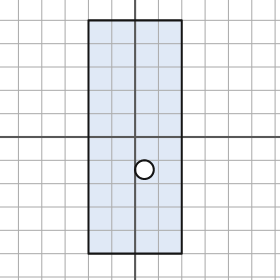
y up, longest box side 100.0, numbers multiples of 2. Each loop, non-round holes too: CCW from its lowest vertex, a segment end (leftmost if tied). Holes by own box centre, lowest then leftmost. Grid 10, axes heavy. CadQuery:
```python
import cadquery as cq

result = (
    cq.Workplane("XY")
    .moveTo(-20.0, -50.0)
    .lineTo(20.0, -50.0)
    .lineTo(20.0, 50.0)
    .lineTo(-20.0, 50.0)
    .close()
    .moveTo(4.0, -14.0)
    .circle(4.0)
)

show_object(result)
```